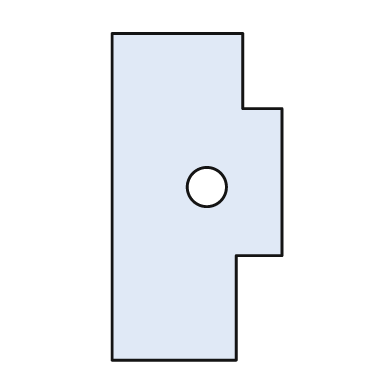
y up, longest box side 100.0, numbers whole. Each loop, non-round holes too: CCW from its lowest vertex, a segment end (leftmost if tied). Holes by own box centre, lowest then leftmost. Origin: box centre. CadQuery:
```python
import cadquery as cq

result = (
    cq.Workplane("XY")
    .moveTo(-26.0, -50.0)
    .lineTo(12.0, -50.0)
    .lineTo(12.0, -18.0)
    .lineTo(26.0, -18.0)
    .lineTo(26.0, 27.0)
    .lineTo(14.0, 27.0)
    .lineTo(14.0, 50.0)
    .lineTo(-26.0, 50.0)
    .close()
    .moveTo(3.0, 3.0)
    .circle(6.0)
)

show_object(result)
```